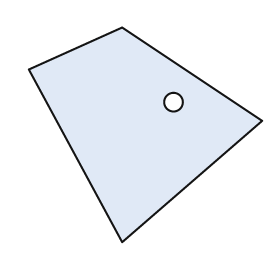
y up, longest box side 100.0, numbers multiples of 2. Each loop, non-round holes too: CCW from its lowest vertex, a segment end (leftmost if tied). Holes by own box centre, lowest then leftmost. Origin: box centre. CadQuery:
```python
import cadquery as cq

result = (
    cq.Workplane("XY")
    .moveTo(-10.0, -46.0)
    .lineTo(50.0, 6.0)
    .lineTo(-10.0, 46.0)
    .lineTo(-50.0, 28.0)
    .close()
    .moveTo(12.0, 14.0)
    .circle(4.0)
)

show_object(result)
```